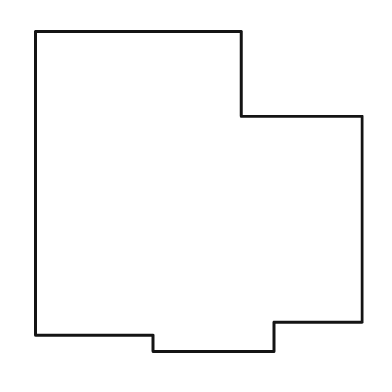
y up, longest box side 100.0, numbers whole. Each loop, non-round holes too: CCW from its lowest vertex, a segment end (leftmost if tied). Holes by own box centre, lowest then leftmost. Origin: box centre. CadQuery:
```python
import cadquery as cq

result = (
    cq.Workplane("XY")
    .moveTo(-14.0, -49.0)
    .lineTo(23.0, -49.0)
    .lineTo(23.0, -40.0)
    .lineTo(50.0, -40.0)
    .lineTo(50.0, 23.0)
    .lineTo(13.0, 23.0)
    .lineTo(13.0, 49.0)
    .lineTo(-50.0, 49.0)
    .lineTo(-50.0, -44.0)
    .lineTo(-14.0, -44.0)
    .close()
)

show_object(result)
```